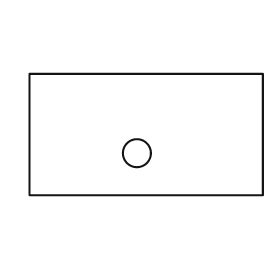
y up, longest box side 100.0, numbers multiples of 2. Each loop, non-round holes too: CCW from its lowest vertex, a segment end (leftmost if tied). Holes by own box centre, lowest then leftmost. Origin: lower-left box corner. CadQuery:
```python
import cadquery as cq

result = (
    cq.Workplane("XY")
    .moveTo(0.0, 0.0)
    .lineTo(100.0, 0.0)
    .lineTo(100.0, 52.0)
    .lineTo(0.0, 52.0)
    .close()
    .moveTo(46.0, 18.0)
    .circle(6.0)
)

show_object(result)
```